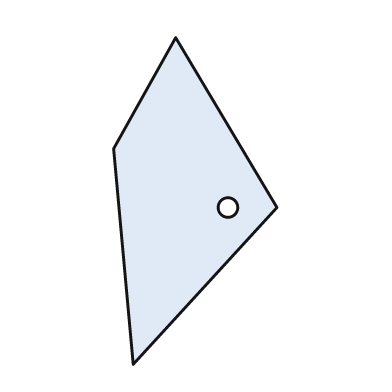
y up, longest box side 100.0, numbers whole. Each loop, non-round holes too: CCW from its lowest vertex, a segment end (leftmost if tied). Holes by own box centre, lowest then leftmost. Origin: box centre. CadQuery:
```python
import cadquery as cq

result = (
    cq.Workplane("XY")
    .moveTo(-19.0, -50.0)
    .lineTo(25.0, -2.0)
    .lineTo(-6.0, 50.0)
    .lineTo(-25.0, 16.0)
    .close()
    .moveTo(10.0, -2.0)
    .circle(3.0)
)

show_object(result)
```